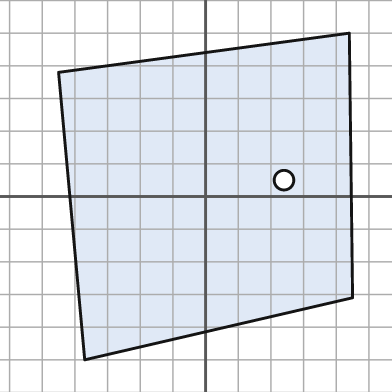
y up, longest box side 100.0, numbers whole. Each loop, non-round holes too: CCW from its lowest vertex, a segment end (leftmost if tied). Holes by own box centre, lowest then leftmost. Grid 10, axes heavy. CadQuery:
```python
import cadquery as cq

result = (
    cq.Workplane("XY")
    .moveTo(-37.0, -50.0)
    .lineTo(45.0, -31.0)
    .lineTo(44.0, 50.0)
    .lineTo(-45.0, 38.0)
    .close()
    .moveTo(24.0, 5.0)
    .circle(3.0)
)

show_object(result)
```